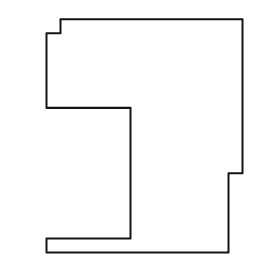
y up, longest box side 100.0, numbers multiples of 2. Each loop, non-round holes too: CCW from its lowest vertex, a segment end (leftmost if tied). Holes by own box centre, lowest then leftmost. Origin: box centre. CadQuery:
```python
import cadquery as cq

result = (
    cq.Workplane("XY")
    .moveTo(-42.0, -50.0)
    .lineTo(36.0, -50.0)
    .lineTo(36.0, -16.0)
    .lineTo(42.0, -16.0)
    .lineTo(42.0, 50.0)
    .lineTo(-36.0, 50.0)
    .lineTo(-36.0, 44.0)
    .lineTo(-42.0, 44.0)
    .lineTo(-42.0, 12.0)
    .lineTo(-6.0, 12.0)
    .lineTo(-6.0, -44.0)
    .lineTo(-42.0, -44.0)
    .close()
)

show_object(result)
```